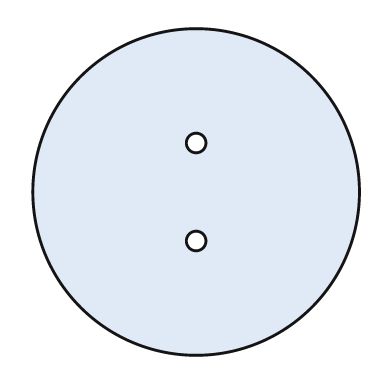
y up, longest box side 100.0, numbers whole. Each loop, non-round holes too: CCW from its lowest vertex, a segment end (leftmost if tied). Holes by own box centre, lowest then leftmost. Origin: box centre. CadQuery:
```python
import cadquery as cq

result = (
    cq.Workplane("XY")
    .moveTo(0.0, 0.0)
    .circle(50.0)
    .moveTo(0.0, -15.0)
    .circle(3.0)
    .moveTo(0.0, 15.0)
    .circle(3.0)
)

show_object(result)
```